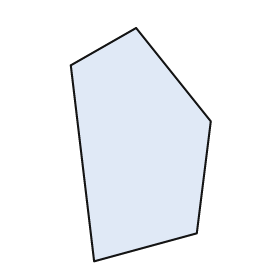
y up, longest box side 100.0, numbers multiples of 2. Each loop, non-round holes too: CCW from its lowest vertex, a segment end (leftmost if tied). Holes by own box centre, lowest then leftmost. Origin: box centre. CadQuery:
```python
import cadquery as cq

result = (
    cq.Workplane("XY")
    .moveTo(-20.0, -50.0)
    .lineTo(24.0, -38.0)
    .lineTo(30.0, 10.0)
    .lineTo(-2.0, 50.0)
    .lineTo(-30.0, 34.0)
    .close()
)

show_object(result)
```